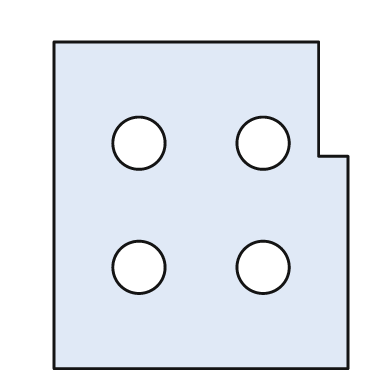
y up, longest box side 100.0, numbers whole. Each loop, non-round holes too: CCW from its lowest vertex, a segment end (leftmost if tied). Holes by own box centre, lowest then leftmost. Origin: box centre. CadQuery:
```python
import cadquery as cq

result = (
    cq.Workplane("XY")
    .moveTo(-45.0, -50.0)
    .lineTo(45.0, -50.0)
    .lineTo(45.0, 15.0)
    .lineTo(36.0, 15.0)
    .lineTo(36.0, 50.0)
    .lineTo(-45.0, 50.0)
    .close()
    .moveTo(-19.0, -19.0)
    .circle(8.0)
    .moveTo(19.0, -19.0)
    .circle(8.0)
    .moveTo(-19.0, 19.0)
    .circle(8.0)
    .moveTo(19.0, 19.0)
    .circle(8.0)
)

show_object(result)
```